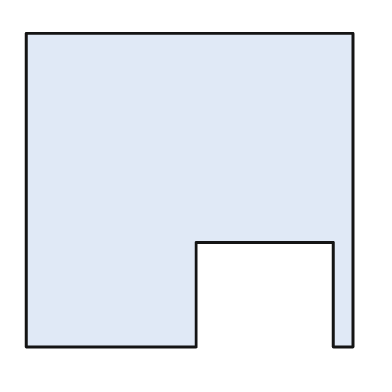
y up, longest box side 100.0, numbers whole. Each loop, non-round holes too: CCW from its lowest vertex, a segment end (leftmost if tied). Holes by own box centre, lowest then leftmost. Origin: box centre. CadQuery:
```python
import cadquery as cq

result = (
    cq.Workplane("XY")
    .moveTo(-50.0, -48.0)
    .lineTo(2.0, -48.0)
    .lineTo(2.0, -16.0)
    .lineTo(44.0, -16.0)
    .lineTo(44.0, -48.0)
    .lineTo(50.0, -48.0)
    .lineTo(50.0, 48.0)
    .lineTo(-50.0, 48.0)
    .close()
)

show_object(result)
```